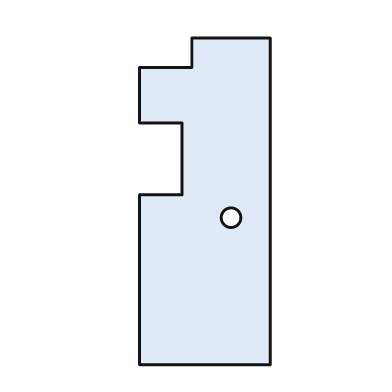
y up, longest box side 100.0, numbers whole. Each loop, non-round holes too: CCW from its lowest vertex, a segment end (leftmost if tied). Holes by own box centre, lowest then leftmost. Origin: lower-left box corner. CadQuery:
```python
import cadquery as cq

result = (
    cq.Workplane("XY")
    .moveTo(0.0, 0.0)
    .lineTo(40.0, 0.0)
    .lineTo(40.0, 100.0)
    .lineTo(16.0, 100.0)
    .lineTo(16.0, 91.0)
    .lineTo(0.0, 91.0)
    .lineTo(0.0, 74.0)
    .lineTo(13.0, 74.0)
    .lineTo(13.0, 52.0)
    .lineTo(0.0, 52.0)
    .close()
    .moveTo(28.0, 45.0)
    .circle(3.0)
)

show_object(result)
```